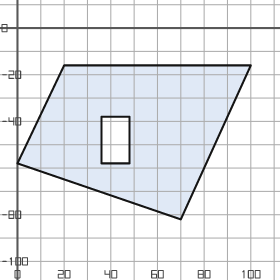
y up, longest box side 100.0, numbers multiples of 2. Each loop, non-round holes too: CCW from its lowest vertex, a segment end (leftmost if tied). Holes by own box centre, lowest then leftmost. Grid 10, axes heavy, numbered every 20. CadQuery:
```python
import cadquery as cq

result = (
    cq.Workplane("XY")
    .moveTo(70.0, -82.0)
    .lineTo(100.0, -16.0)
    .lineTo(20.0, -16.0)
    .lineTo(0.0, -58.0)
    .close()
    .moveTo(36.0, -58.0)
    .lineTo(48.0, -58.0)
    .lineTo(48.0, -38.0)
    .lineTo(36.0, -38.0)
    .close()
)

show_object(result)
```